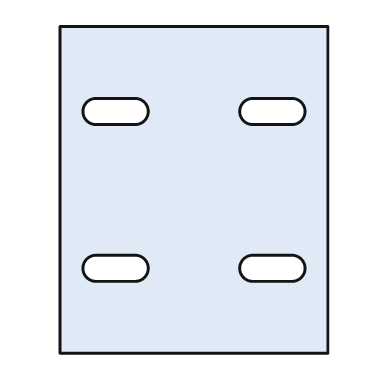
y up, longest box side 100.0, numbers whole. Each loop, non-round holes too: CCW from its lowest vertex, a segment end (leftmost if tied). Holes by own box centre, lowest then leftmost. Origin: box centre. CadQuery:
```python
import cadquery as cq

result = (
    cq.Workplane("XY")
    .moveTo(-41.0, -50.0)
    .lineTo(41.0, -50.0)
    .lineTo(41.0, 50.0)
    .lineTo(-41.0, 50.0)
    .close()
    .moveTo(-30.0, -28.0)
    .lineTo(-18.0, -28.0)
    .threePointArc((-14.0, -24.0), (-18.0, -20.0))
    .lineTo(-30.0, -20.0)
    .threePointArc((-34.0, -24.0), (-30.0, -28.0))
    .close()
    .moveTo(18.0, -28.0)
    .lineTo(30.0, -28.0)
    .threePointArc((34.0, -24.0), (30.0, -20.0))
    .lineTo(18.0, -20.0)
    .threePointArc((14.0, -24.0), (18.0, -28.0))
    .close()
    .moveTo(-30.0, 20.0)
    .lineTo(-18.0, 20.0)
    .threePointArc((-14.0, 24.0), (-18.0, 28.0))
    .lineTo(-30.0, 28.0)
    .threePointArc((-34.0, 24.0), (-30.0, 20.0))
    .close()
    .moveTo(18.0, 20.0)
    .lineTo(30.0, 20.0)
    .threePointArc((34.0, 24.0), (30.0, 28.0))
    .lineTo(18.0, 28.0)
    .threePointArc((14.0, 24.0), (18.0, 20.0))
    .close()
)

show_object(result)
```